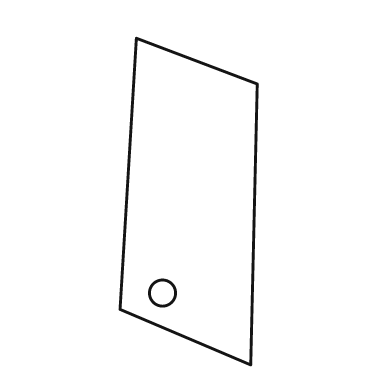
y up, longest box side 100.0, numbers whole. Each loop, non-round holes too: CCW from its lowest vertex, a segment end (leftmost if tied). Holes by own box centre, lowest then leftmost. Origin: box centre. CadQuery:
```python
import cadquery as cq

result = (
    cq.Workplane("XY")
    .moveTo(19.0, -50.0)
    .lineTo(21.0, 36.0)
    .lineTo(-16.0, 50.0)
    .lineTo(-21.0, -33.0)
    .close()
    .moveTo(-8.0, -28.0)
    .circle(4.0)
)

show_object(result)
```